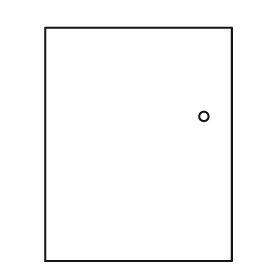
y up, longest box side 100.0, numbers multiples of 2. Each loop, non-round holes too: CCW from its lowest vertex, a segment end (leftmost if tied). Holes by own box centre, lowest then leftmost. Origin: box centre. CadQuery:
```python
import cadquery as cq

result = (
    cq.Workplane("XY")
    .moveTo(-40.0, -50.0)
    .lineTo(40.0, -50.0)
    .lineTo(40.0, 50.0)
    .lineTo(-40.0, 50.0)
    .close()
    .moveTo(28.0, 12.0)
    .circle(2.0)
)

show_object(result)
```